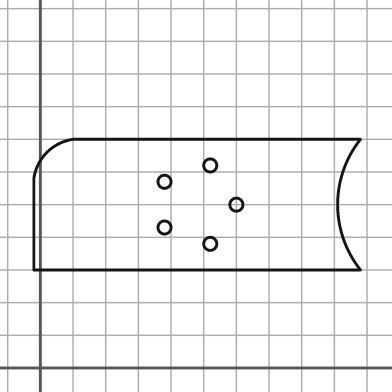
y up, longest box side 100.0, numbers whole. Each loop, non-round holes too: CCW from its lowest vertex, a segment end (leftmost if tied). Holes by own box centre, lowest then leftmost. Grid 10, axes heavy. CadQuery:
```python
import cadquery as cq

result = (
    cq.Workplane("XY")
    .moveTo(-2.0, 30.0)
    .lineTo(98.0, 30.0)
    .threePointArc((91.0, 50.0), (98.0, 70.0))
    .lineTo(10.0, 70.0)
    .threePointArc((2.0, 66.0), (-2.0, 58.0))
    .close()
    .moveTo(52.0, 38.0)
    .circle(2.0)
    .moveTo(38.0, 43.0)
    .circle(2.0)
    .moveTo(60.0, 50.0)
    .circle(2.0)
    .moveTo(38.0, 57.0)
    .circle(2.0)
    .moveTo(52.0, 62.0)
    .circle(2.0)
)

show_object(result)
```